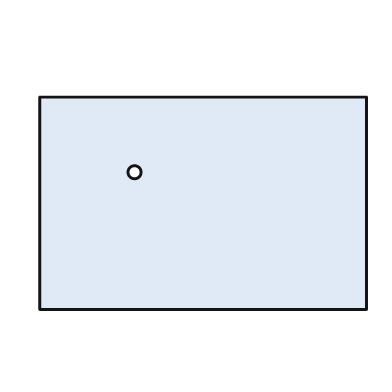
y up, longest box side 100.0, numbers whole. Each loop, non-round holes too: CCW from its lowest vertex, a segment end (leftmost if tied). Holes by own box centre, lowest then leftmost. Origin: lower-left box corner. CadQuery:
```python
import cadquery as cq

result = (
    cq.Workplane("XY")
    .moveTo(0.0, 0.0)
    .lineTo(100.0, 0.0)
    .lineTo(100.0, 65.0)
    .lineTo(0.0, 65.0)
    .close()
    .moveTo(29.0, 42.0)
    .circle(2.0)
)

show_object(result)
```